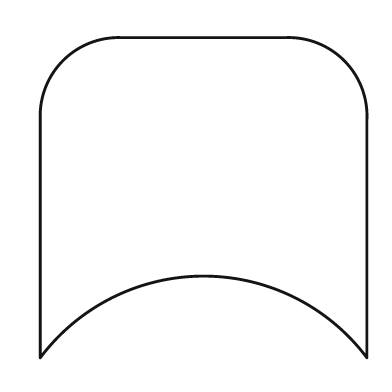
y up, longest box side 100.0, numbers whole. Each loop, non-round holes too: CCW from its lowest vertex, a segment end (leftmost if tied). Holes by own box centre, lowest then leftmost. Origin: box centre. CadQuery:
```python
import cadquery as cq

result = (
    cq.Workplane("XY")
    .moveTo(-50.0, -49.0)
    .threePointArc((0.0, -24.0), (50.0, -49.0))
    .lineTo(50.0, 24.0)
    .threePointArc((43.0, 42.0), (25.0, 49.0))
    .lineTo(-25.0, 49.0)
    .threePointArc((-43.0, 42.0), (-50.0, 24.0))
    .close()
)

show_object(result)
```